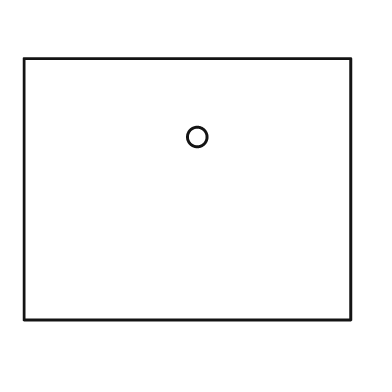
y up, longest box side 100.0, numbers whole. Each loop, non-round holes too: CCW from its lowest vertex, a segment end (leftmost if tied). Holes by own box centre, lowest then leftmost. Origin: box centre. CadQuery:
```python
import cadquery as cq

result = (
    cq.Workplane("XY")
    .moveTo(-50.0, -40.0)
    .lineTo(50.0, -40.0)
    .lineTo(50.0, 40.0)
    .lineTo(-50.0, 40.0)
    .close()
    .moveTo(3.0, 16.0)
    .circle(3.0)
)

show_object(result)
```